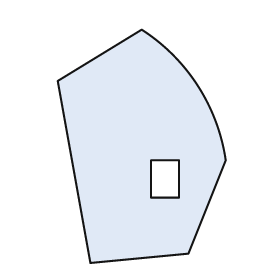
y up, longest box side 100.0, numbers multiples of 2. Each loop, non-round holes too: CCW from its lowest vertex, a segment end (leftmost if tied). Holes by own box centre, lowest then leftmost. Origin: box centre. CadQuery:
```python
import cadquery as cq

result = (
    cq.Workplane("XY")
    .moveTo(-22.0, -50.0)
    .lineTo(20.0, -46.0)
    .lineTo(36.0, -6.0)
    .threePointArc((24.0, 26.0), (0.0, 50.0))
    .lineTo(-36.0, 28.0)
    .close()
    .moveTo(4.0, -22.0)
    .lineTo(16.0, -22.0)
    .lineTo(16.0, -6.0)
    .lineTo(4.0, -6.0)
    .close()
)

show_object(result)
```